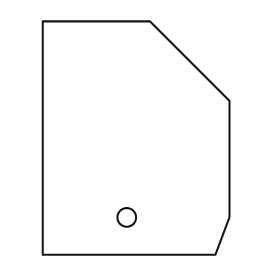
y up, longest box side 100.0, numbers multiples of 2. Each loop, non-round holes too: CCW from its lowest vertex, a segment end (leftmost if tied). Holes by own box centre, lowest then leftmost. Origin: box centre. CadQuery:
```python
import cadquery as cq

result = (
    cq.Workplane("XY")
    .moveTo(-40.0, -50.0)
    .lineTo(34.0, -50.0)
    .lineTo(40.0, -34.0)
    .lineTo(40.0, 16.0)
    .lineTo(6.0, 50.0)
    .lineTo(-40.0, 50.0)
    .close()
    .moveTo(-4.0, -34.0)
    .circle(4.0)
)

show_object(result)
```